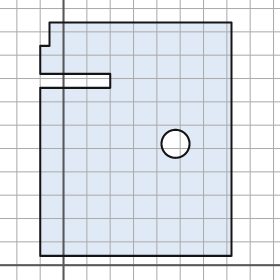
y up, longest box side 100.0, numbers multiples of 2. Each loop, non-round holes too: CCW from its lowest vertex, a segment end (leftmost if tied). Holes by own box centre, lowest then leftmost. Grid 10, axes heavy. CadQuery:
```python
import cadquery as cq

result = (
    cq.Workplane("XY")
    .moveTo(-10.0, 4.0)
    .lineTo(72.0, 4.0)
    .lineTo(72.0, 104.0)
    .lineTo(-6.0, 104.0)
    .lineTo(-6.0, 94.0)
    .lineTo(-10.0, 94.0)
    .lineTo(-10.0, 82.0)
    .lineTo(20.0, 82.0)
    .lineTo(20.0, 76.0)
    .lineTo(-10.0, 76.0)
    .close()
    .moveTo(48.0, 52.0)
    .circle(6.0)
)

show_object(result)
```